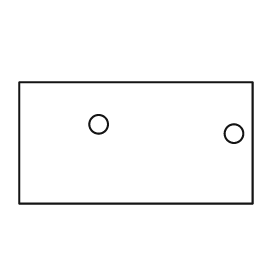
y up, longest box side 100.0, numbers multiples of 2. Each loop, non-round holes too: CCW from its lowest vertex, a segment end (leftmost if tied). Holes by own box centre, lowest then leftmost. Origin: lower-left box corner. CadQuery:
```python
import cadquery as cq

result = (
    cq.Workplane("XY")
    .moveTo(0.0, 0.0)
    .lineTo(100.0, 0.0)
    .lineTo(100.0, 52.0)
    .lineTo(0.0, 52.0)
    .close()
    .moveTo(92.0, 30.0)
    .circle(4.0)
    .moveTo(34.0, 34.0)
    .circle(4.0)
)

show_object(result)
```